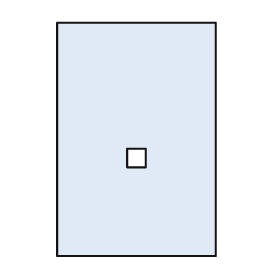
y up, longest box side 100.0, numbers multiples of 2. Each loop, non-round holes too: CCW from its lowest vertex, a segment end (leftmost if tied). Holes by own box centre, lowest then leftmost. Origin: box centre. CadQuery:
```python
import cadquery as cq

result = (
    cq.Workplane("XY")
    .moveTo(-34.0, -50.0)
    .lineTo(34.0, -50.0)
    .lineTo(34.0, 50.0)
    .lineTo(-34.0, 50.0)
    .close()
    .moveTo(-4.0, -12.0)
    .lineTo(4.0, -12.0)
    .lineTo(4.0, -4.0)
    .lineTo(-4.0, -4.0)
    .close()
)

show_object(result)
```